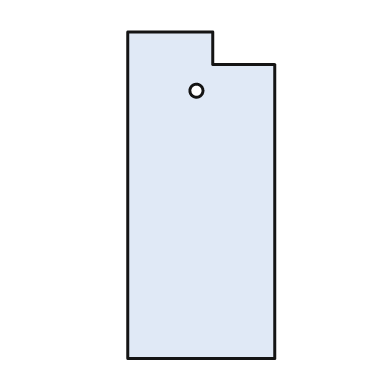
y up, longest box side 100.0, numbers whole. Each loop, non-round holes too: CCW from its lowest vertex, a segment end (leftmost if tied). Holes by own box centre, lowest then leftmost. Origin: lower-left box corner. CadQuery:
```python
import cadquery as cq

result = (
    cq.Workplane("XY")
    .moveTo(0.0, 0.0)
    .lineTo(45.0, 0.0)
    .lineTo(45.0, 90.0)
    .lineTo(26.0, 90.0)
    .lineTo(26.0, 100.0)
    .lineTo(0.0, 100.0)
    .close()
    .moveTo(21.0, 82.0)
    .circle(2.0)
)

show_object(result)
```